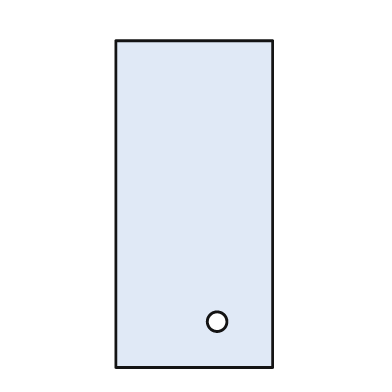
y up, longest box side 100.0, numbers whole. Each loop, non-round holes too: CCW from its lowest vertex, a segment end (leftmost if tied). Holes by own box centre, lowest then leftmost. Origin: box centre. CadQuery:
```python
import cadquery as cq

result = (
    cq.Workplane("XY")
    .moveTo(-24.0, -50.0)
    .lineTo(24.0, -50.0)
    .lineTo(24.0, 50.0)
    .lineTo(-24.0, 50.0)
    .close()
    .moveTo(7.0, -36.0)
    .circle(3.0)
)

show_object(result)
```